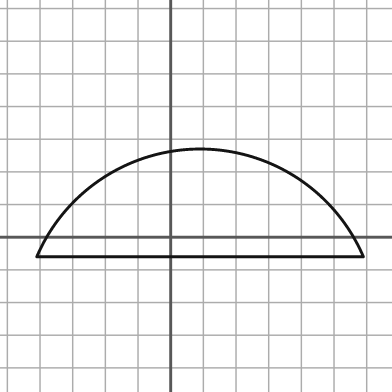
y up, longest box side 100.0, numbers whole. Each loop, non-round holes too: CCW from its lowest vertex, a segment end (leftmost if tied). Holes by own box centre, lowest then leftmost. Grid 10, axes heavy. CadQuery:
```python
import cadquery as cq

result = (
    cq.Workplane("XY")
    .moveTo(-41.0, -6.0)
    .lineTo(59.0, -6.0)
    .threePointArc((9.0, 27.0), (-41.0, -6.0))
    .close()
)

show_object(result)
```